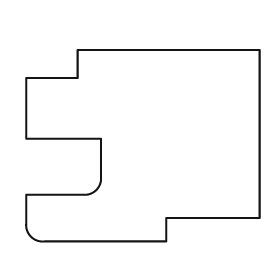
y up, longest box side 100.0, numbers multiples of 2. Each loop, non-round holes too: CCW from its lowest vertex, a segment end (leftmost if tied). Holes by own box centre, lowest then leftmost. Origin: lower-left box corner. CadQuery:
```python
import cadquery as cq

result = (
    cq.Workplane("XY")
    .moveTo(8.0, 0.0)
    .lineTo(60.0, 0.0)
    .lineTo(60.0, 10.0)
    .lineTo(100.0, 10.0)
    .lineTo(100.0, 82.0)
    .lineTo(22.0, 82.0)
    .lineTo(22.0, 70.0)
    .lineTo(0.0, 70.0)
    .lineTo(0.0, 44.0)
    .lineTo(32.0, 44.0)
    .lineTo(32.0, 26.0)
    .threePointArc((30.0, 22.0), (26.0, 20.0))
    .lineTo(0.0, 20.0)
    .lineTo(0.0, 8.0)
    .threePointArc((2.0, 2.0), (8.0, 0.0))
    .close()
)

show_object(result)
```